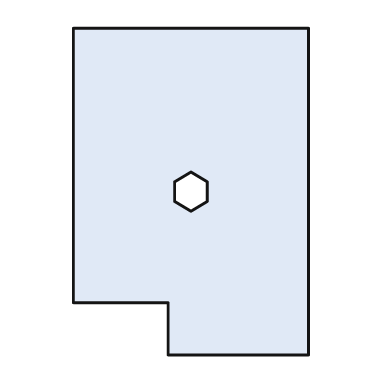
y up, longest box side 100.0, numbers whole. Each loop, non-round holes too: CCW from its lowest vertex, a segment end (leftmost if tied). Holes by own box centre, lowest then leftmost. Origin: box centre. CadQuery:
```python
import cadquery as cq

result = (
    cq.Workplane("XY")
    .moveTo(-7.0, -50.0)
    .lineTo(36.0, -50.0)
    .lineTo(36.0, 50.0)
    .lineTo(-36.0, 50.0)
    .lineTo(-36.0, -34.0)
    .lineTo(-7.0, -34.0)
    .close()
    .moveTo(0.0, -6.0)
    .lineTo(5.0, -3.0)
    .lineTo(5.0, 3.0)
    .lineTo(0.0, 6.0)
    .lineTo(-5.0, 3.0)
    .lineTo(-5.0, -3.0)
    .close()
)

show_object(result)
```